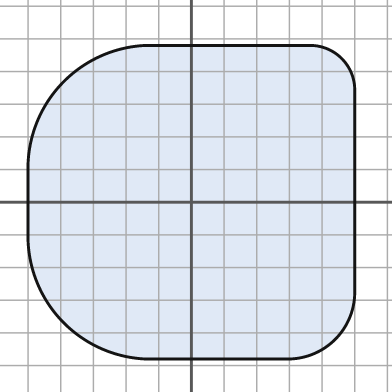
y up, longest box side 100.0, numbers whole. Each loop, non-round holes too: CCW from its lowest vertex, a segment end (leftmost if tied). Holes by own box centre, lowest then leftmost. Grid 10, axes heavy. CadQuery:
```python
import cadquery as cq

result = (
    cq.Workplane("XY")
    .moveTo(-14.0, -48.0)
    .lineTo(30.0, -48.0)
    .threePointArc((44.0, -42.0), (50.0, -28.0))
    .lineTo(50.0, 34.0)
    .threePointArc((46.0, 44.0), (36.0, 48.0))
    .lineTo(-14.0, 48.0)
    .threePointArc((-39.0, 37.0), (-50.0, 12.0))
    .lineTo(-50.0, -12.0)
    .threePointArc((-39.0, -37.0), (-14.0, -48.0))
    .close()
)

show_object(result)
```